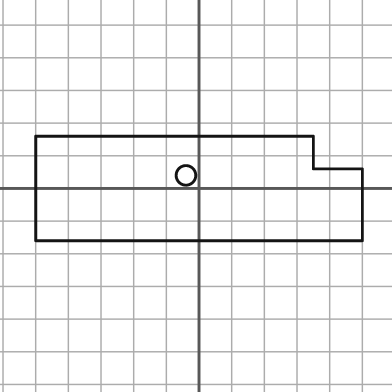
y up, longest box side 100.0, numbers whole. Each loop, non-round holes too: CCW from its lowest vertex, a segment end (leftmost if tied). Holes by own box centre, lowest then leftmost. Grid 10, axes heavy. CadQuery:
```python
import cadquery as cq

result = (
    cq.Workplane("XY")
    .moveTo(-50.0, -16.0)
    .lineTo(50.0, -16.0)
    .lineTo(50.0, 6.0)
    .lineTo(35.0, 6.0)
    .lineTo(35.0, 16.0)
    .lineTo(-50.0, 16.0)
    .close()
    .moveTo(-4.0, 4.0)
    .circle(3.0)
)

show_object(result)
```